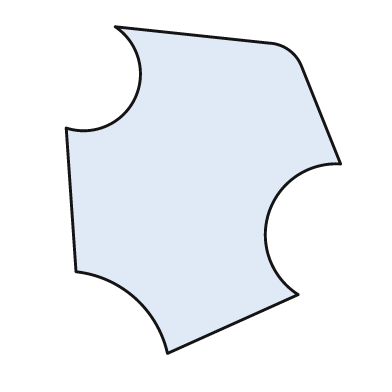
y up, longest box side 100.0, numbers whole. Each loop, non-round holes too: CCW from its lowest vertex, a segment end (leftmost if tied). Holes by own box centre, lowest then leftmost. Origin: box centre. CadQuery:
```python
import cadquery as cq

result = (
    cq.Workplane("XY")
    .moveTo(-11.0, -50.0)
    .lineTo(29.0, -32.0)
    .threePointArc((20.0, -7.0), (42.0, 8.0))
    .lineTo(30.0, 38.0)
    .threePointArc((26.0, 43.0), (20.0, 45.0))
    .lineTo(-27.0, 50.0)
    .threePointArc((-21.0, 28.0), (-42.0, 19.0))
    .lineTo(-39.0, -25.0)
    .threePointArc((-21.0, -33.0), (-11.0, -50.0))
    .close()
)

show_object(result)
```